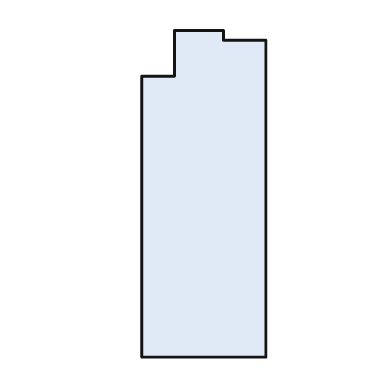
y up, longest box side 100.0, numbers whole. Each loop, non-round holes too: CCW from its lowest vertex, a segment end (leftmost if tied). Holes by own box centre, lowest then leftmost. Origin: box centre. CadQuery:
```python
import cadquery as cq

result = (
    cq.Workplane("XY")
    .moveTo(-19.0, -50.0)
    .lineTo(19.0, -50.0)
    .lineTo(19.0, 47.0)
    .lineTo(6.0, 47.0)
    .lineTo(6.0, 50.0)
    .lineTo(-9.0, 50.0)
    .lineTo(-9.0, 36.0)
    .lineTo(-19.0, 36.0)
    .close()
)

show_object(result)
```